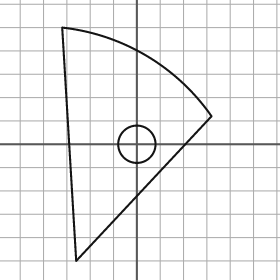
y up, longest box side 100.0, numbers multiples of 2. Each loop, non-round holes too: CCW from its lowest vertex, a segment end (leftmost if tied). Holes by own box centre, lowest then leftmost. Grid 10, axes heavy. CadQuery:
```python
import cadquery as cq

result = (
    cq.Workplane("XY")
    .moveTo(-26.0, -50.0)
    .lineTo(32.0, 12.0)
    .threePointArc((4.0, 38.0), (-32.0, 50.0))
    .close()
    .moveTo(0.0, 0.0)
    .circle(8.0)
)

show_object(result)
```